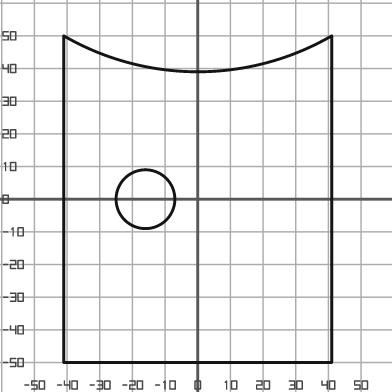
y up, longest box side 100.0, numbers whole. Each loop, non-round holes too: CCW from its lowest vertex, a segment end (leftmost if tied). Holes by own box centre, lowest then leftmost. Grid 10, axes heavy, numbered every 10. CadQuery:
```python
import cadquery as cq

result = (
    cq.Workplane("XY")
    .moveTo(-41.0, -50.0)
    .lineTo(41.0, -50.0)
    .lineTo(41.0, 50.0)
    .threePointArc((0.0, 39.0), (-41.0, 50.0))
    .close()
    .moveTo(-16.0, 0.0)
    .circle(9.0)
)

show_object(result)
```